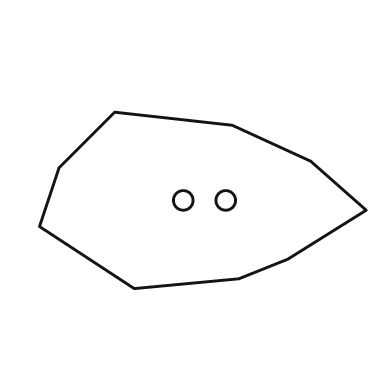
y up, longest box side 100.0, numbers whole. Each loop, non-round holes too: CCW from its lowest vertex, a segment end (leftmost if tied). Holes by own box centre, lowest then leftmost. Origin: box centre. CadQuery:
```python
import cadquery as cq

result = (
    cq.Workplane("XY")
    .moveTo(-21.0, -27.0)
    .lineTo(11.0, -24.0)
    .lineTo(26.0, -18.0)
    .lineTo(50.0, -3.0)
    .lineTo(33.0, 12.0)
    .lineTo(9.0, 23.0)
    .lineTo(-27.0, 27.0)
    .lineTo(-44.0, 10.0)
    .lineTo(-50.0, -8.0)
    .close()
    .moveTo(-6.0, 0.0)
    .circle(3.0)
    .moveTo(7.0, 0.0)
    .circle(3.0)
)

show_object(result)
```